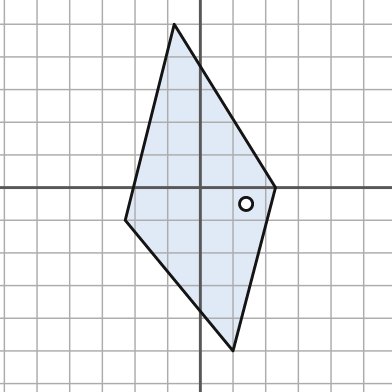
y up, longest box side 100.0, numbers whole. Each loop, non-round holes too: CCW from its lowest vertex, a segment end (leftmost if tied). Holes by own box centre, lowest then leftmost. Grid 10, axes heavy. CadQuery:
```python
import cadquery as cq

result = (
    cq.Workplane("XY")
    .moveTo(10.0, -50.0)
    .lineTo(23.0, 0.0)
    .lineTo(-8.0, 50.0)
    .lineTo(-23.0, -10.0)
    .close()
    .moveTo(14.0, -5.0)
    .circle(2.0)
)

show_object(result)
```